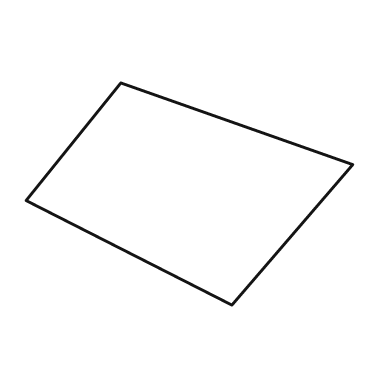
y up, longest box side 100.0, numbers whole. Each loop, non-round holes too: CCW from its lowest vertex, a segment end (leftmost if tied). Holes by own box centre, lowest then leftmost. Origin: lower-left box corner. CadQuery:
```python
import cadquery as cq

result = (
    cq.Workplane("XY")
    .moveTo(63.0, 0.0)
    .lineTo(100.0, 43.0)
    .lineTo(29.0, 68.0)
    .lineTo(0.0, 32.0)
    .close()
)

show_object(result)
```